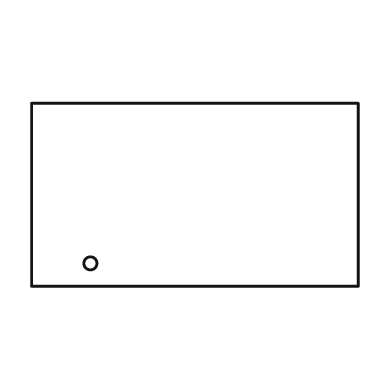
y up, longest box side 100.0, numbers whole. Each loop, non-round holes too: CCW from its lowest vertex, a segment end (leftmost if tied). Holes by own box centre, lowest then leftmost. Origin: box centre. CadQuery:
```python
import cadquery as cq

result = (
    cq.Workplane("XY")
    .moveTo(-50.0, -28.0)
    .lineTo(50.0, -28.0)
    .lineTo(50.0, 28.0)
    .lineTo(-50.0, 28.0)
    .close()
    .moveTo(-32.0, -21.0)
    .circle(2.0)
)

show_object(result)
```